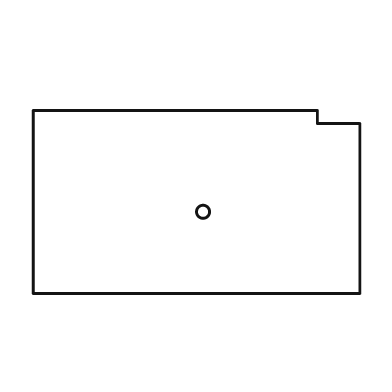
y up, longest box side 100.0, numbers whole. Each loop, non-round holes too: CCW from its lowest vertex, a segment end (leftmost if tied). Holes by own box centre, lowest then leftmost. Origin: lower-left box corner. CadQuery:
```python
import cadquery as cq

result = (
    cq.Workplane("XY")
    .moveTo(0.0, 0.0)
    .lineTo(100.0, 0.0)
    .lineTo(100.0, 52.0)
    .lineTo(87.0, 52.0)
    .lineTo(87.0, 56.0)
    .lineTo(0.0, 56.0)
    .close()
    .moveTo(52.0, 25.0)
    .circle(2.0)
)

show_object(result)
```